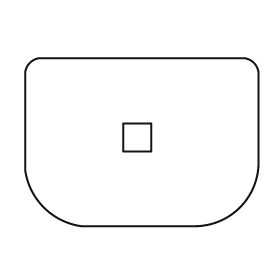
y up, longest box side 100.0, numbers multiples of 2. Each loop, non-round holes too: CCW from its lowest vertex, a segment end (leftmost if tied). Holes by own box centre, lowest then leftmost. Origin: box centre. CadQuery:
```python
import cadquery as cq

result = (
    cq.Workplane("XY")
    .moveTo(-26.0, -36.0)
    .lineTo(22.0, -36.0)
    .threePointArc((42.0, -28.0), (50.0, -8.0))
    .lineTo(50.0, 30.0)
    .threePointArc((48.0, 34.0), (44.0, 36.0))
    .lineTo(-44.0, 36.0)
    .threePointArc((-48.0, 34.0), (-50.0, 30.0))
    .lineTo(-50.0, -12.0)
    .threePointArc((-42.0, -28.0), (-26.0, -36.0))
    .close()
    .moveTo(-8.0, -4.0)
    .lineTo(4.0, -4.0)
    .lineTo(4.0, 8.0)
    .lineTo(-8.0, 8.0)
    .close()
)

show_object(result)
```